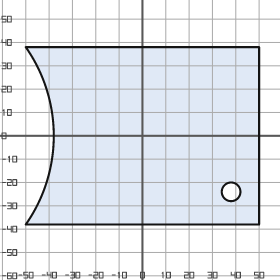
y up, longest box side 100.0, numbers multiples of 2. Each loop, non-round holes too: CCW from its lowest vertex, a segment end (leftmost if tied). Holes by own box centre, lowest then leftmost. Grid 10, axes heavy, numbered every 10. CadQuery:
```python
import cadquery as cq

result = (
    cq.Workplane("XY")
    .moveTo(-50.0, -38.0)
    .lineTo(50.0, -38.0)
    .lineTo(50.0, 38.0)
    .lineTo(-50.0, 38.0)
    .threePointArc((-38.0, 0.0), (-50.0, -38.0))
    .close()
    .moveTo(38.0, -24.0)
    .circle(4.0)
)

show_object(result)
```